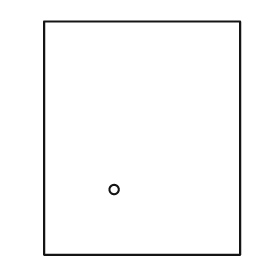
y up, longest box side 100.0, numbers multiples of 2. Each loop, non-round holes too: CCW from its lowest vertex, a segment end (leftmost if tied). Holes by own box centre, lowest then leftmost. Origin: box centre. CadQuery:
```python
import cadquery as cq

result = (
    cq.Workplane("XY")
    .moveTo(-42.0, -50.0)
    .lineTo(42.0, -50.0)
    .lineTo(42.0, 50.0)
    .lineTo(-42.0, 50.0)
    .close()
    .moveTo(-12.0, -22.0)
    .circle(2.0)
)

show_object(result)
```